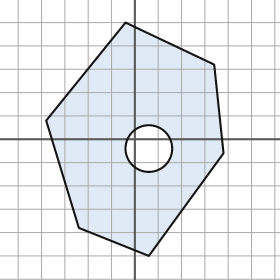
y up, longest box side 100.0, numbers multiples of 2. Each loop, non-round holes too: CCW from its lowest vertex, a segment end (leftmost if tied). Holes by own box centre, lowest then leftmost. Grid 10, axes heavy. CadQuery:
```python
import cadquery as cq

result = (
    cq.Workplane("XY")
    .moveTo(6.0, -50.0)
    .lineTo(38.0, -6.0)
    .lineTo(34.0, 32.0)
    .lineTo(-4.0, 50.0)
    .lineTo(-38.0, 8.0)
    .lineTo(-24.0, -38.0)
    .close()
    .moveTo(6.0, -4.0)
    .circle(10.0)
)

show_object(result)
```